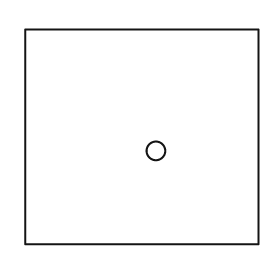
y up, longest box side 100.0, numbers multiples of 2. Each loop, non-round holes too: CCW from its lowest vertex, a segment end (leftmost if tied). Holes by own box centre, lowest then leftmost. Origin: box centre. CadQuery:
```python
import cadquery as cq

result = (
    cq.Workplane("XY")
    .moveTo(-50.0, -46.0)
    .lineTo(50.0, -46.0)
    .lineTo(50.0, 46.0)
    .lineTo(-50.0, 46.0)
    .close()
    .moveTo(6.0, -6.0)
    .circle(4.0)
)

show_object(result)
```